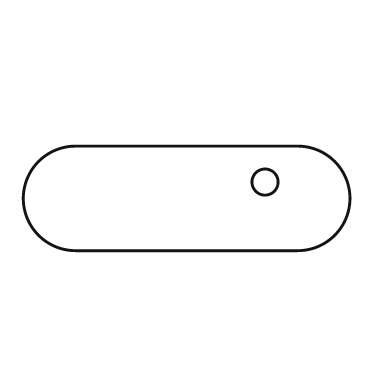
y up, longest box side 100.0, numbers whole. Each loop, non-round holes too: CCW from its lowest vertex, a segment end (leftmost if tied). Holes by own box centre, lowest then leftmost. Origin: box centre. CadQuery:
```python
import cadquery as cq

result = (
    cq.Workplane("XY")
    .moveTo(-34.0, -16.0)
    .lineTo(34.0, -16.0)
    .threePointArc((50.0, 0.0), (34.0, 16.0))
    .lineTo(-34.0, 16.0)
    .threePointArc((-50.0, 0.0), (-34.0, -16.0))
    .close()
    .moveTo(24.0, 5.0)
    .circle(4.0)
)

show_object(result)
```